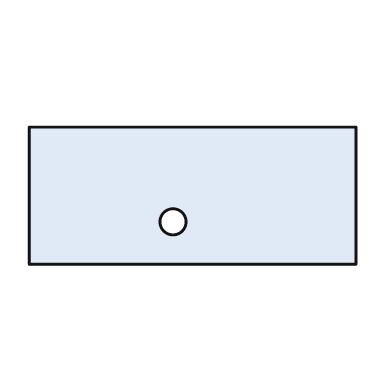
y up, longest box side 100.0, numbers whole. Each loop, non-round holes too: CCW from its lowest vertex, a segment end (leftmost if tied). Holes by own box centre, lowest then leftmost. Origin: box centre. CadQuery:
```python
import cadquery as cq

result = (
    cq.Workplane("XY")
    .moveTo(-50.0, -21.0)
    .lineTo(50.0, -21.0)
    .lineTo(50.0, 21.0)
    .lineTo(-50.0, 21.0)
    .close()
    .moveTo(-6.0, -8.0)
    .circle(4.0)
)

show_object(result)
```